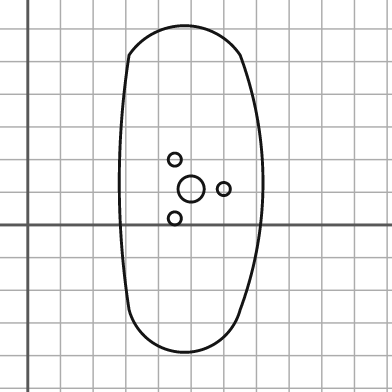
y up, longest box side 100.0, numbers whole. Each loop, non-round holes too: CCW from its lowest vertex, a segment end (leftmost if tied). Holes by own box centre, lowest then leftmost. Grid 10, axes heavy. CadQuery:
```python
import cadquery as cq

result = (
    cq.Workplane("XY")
    .moveTo(31.0, -26.0)
    .threePointArc((48.0, -39.0), (65.0, -26.0))
    .threePointArc((72.0, 13.0), (65.0, 52.0))
    .threePointArc((48.0, 61.0), (31.0, 52.0))
    .threePointArc((28.0, 13.0), (31.0, -26.0))
    .close()
    .moveTo(45.0, 2.0)
    .circle(2.0)
    .moveTo(50.0, 11.0)
    .circle(4.0)
    .moveTo(60.0, 11.0)
    .circle(2.0)
    .moveTo(45.0, 20.0)
    .circle(2.0)
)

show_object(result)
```